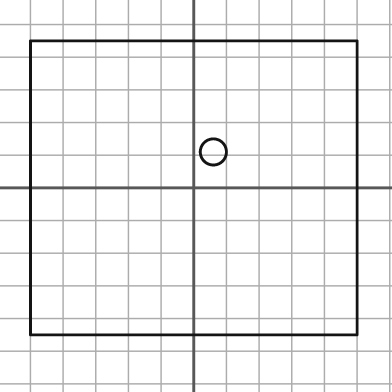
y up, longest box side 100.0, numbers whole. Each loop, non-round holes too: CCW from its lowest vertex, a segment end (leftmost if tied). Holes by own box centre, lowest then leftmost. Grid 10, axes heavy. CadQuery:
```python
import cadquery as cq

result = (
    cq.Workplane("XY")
    .moveTo(-50.0, -45.0)
    .lineTo(50.0, -45.0)
    .lineTo(50.0, 45.0)
    .lineTo(-50.0, 45.0)
    .close()
    .moveTo(6.0, 11.0)
    .circle(4.0)
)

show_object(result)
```